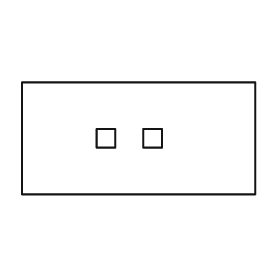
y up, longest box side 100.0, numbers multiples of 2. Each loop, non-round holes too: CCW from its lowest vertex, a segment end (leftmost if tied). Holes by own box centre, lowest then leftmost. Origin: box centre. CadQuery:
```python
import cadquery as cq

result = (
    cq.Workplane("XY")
    .moveTo(-50.0, -24.0)
    .lineTo(50.0, -24.0)
    .lineTo(50.0, 24.0)
    .lineTo(-50.0, 24.0)
    .close()
    .moveTo(-18.0, -4.0)
    .lineTo(-10.0, -4.0)
    .lineTo(-10.0, 4.0)
    .lineTo(-18.0, 4.0)
    .close()
    .moveTo(2.0, -4.0)
    .lineTo(10.0, -4.0)
    .lineTo(10.0, 4.0)
    .lineTo(2.0, 4.0)
    .close()
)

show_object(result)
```